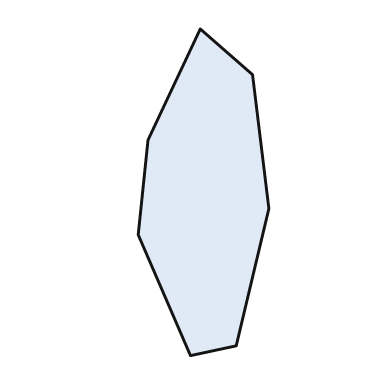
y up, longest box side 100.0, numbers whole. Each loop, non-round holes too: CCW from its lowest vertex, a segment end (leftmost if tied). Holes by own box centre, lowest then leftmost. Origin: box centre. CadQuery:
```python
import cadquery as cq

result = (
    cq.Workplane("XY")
    .moveTo(-4.0, -50.0)
    .lineTo(10.0, -47.0)
    .lineTo(20.0, -5.0)
    .lineTo(15.0, 36.0)
    .lineTo(-1.0, 50.0)
    .lineTo(-17.0, 16.0)
    .lineTo(-20.0, -13.0)
    .close()
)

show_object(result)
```